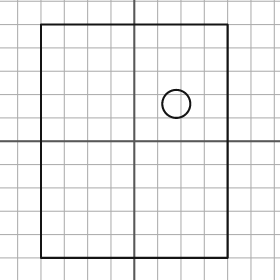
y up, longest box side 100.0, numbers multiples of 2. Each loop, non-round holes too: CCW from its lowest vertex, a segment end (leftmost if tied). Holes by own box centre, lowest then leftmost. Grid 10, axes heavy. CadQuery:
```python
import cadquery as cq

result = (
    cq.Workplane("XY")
    .moveTo(-40.0, -50.0)
    .lineTo(40.0, -50.0)
    .lineTo(40.0, 50.0)
    .lineTo(-40.0, 50.0)
    .close()
    .moveTo(18.0, 16.0)
    .circle(6.0)
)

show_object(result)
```